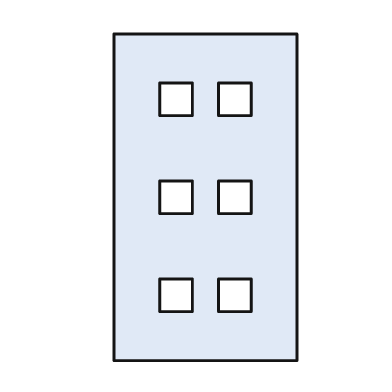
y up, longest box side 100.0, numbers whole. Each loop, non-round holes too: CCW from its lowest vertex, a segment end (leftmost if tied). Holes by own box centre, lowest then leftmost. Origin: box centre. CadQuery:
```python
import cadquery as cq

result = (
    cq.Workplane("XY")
    .moveTo(-28.0, -50.0)
    .lineTo(28.0, -50.0)
    .lineTo(28.0, 50.0)
    .lineTo(-28.0, 50.0)
    .close()
    .moveTo(-14.0, -35.0)
    .lineTo(-4.0, -35.0)
    .lineTo(-4.0, -25.0)
    .lineTo(-14.0, -25.0)
    .close()
    .moveTo(4.0, -35.0)
    .lineTo(14.0, -35.0)
    .lineTo(14.0, -25.0)
    .lineTo(4.0, -25.0)
    .close()
    .moveTo(-14.0, -5.0)
    .lineTo(-4.0, -5.0)
    .lineTo(-4.0, 5.0)
    .lineTo(-14.0, 5.0)
    .close()
    .moveTo(4.0, -5.0)
    .lineTo(14.0, -5.0)
    .lineTo(14.0, 5.0)
    .lineTo(4.0, 5.0)
    .close()
    .moveTo(-14.0, 25.0)
    .lineTo(-4.0, 25.0)
    .lineTo(-4.0, 35.0)
    .lineTo(-14.0, 35.0)
    .close()
    .moveTo(4.0, 25.0)
    .lineTo(14.0, 25.0)
    .lineTo(14.0, 35.0)
    .lineTo(4.0, 35.0)
    .close()
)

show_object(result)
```